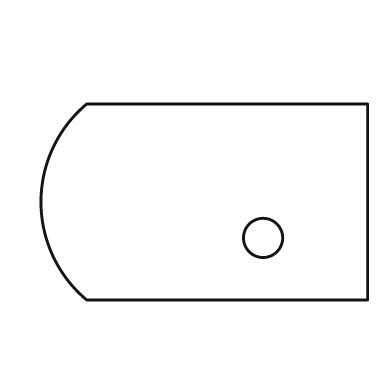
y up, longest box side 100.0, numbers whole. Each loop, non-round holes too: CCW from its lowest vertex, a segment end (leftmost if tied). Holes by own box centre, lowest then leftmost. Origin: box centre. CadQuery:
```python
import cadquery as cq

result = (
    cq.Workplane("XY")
    .moveTo(-36.0, -30.0)
    .lineTo(50.0, -30.0)
    .lineTo(50.0, 30.0)
    .lineTo(-36.0, 30.0)
    .threePointArc((-50.0, 0.0), (-36.0, -30.0))
    .close()
    .moveTo(18.0, -11.0)
    .circle(6.0)
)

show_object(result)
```